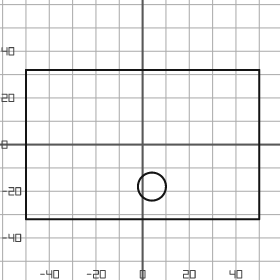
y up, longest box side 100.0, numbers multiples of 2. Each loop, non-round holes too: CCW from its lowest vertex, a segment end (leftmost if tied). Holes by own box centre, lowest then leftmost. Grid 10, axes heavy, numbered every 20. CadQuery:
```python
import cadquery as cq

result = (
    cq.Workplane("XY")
    .moveTo(-50.0, -32.0)
    .lineTo(50.0, -32.0)
    .lineTo(50.0, 32.0)
    .lineTo(-50.0, 32.0)
    .close()
    .moveTo(4.0, -18.0)
    .circle(6.0)
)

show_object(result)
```